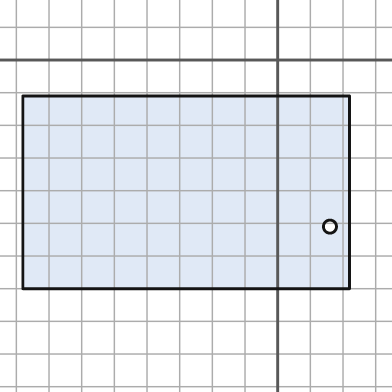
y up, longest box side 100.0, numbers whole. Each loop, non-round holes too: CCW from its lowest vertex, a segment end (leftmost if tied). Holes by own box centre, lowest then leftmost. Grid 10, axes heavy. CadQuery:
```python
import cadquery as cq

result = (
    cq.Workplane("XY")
    .moveTo(-78.0, -70.0)
    .lineTo(22.0, -70.0)
    .lineTo(22.0, -11.0)
    .lineTo(-78.0, -11.0)
    .close()
    .moveTo(16.0, -51.0)
    .circle(2.0)
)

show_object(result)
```